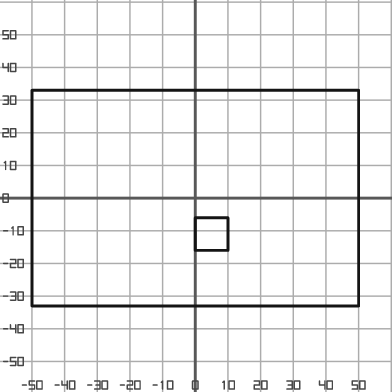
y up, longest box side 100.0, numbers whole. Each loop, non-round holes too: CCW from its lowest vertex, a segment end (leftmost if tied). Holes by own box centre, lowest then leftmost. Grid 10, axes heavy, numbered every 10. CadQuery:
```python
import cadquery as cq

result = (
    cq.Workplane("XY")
    .moveTo(-50.0, -33.0)
    .lineTo(50.0, -33.0)
    .lineTo(50.0, 33.0)
    .lineTo(-50.0, 33.0)
    .close()
    .moveTo(0.0, -16.0)
    .lineTo(10.0, -16.0)
    .lineTo(10.0, -6.0)
    .lineTo(0.0, -6.0)
    .close()
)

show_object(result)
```